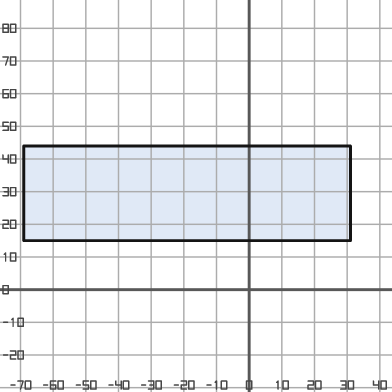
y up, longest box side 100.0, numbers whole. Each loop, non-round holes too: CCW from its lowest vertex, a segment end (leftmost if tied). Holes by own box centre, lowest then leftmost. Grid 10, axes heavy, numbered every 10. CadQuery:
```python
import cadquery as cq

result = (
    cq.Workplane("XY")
    .moveTo(-69.0, 15.0)
    .lineTo(31.0, 15.0)
    .lineTo(31.0, 44.0)
    .lineTo(-69.0, 44.0)
    .close()
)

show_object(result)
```